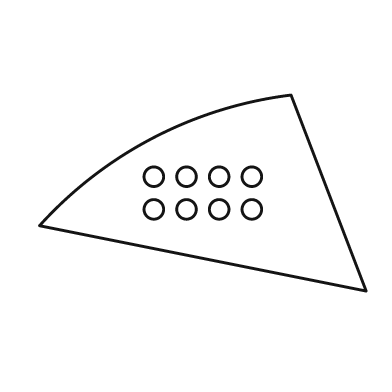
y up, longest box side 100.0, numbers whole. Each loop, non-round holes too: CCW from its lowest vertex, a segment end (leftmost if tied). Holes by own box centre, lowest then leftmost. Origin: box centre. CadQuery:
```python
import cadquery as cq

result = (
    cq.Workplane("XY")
    .moveTo(50.0, -30.0)
    .lineTo(27.0, 30.0)
    .threePointArc((-15.0, 17.0), (-50.0, -10.0))
    .close()
    .moveTo(-15.0, -5.0)
    .circle(3.0)
    .moveTo(-5.0, -5.0)
    .circle(3.0)
    .moveTo(5.0, -5.0)
    .circle(3.0)
    .moveTo(15.0, -5.0)
    .circle(3.0)
    .moveTo(-15.0, 5.0)
    .circle(3.0)
    .moveTo(-5.0, 5.0)
    .circle(3.0)
    .moveTo(5.0, 5.0)
    .circle(3.0)
    .moveTo(15.0, 5.0)
    .circle(3.0)
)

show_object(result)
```